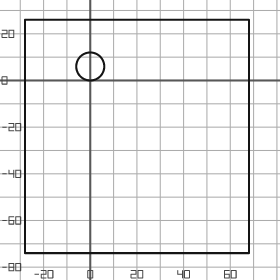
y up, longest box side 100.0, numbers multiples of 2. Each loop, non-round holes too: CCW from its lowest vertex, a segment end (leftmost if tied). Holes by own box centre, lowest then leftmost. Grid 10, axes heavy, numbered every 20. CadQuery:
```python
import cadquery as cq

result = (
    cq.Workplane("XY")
    .moveTo(-28.0, -74.0)
    .lineTo(68.0, -74.0)
    .lineTo(68.0, 26.0)
    .lineTo(-28.0, 26.0)
    .close()
    .moveTo(0.0, 6.0)
    .circle(6.0)
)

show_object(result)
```